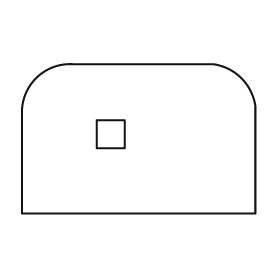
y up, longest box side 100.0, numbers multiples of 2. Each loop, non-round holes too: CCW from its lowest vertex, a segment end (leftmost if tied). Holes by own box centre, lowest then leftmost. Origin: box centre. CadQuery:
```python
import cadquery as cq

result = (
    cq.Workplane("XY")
    .moveTo(-50.0, -32.0)
    .lineTo(50.0, -32.0)
    .lineTo(50.0, 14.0)
    .threePointArc((44.0, 26.0), (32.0, 32.0))
    .lineTo(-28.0, 32.0)
    .threePointArc((-44.0, 26.0), (-50.0, 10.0))
    .close()
    .moveTo(-18.0, -4.0)
    .lineTo(-6.0, -4.0)
    .lineTo(-6.0, 8.0)
    .lineTo(-18.0, 8.0)
    .close()
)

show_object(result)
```